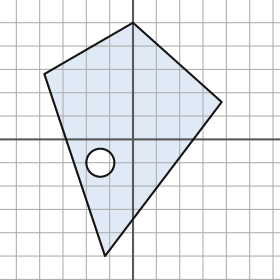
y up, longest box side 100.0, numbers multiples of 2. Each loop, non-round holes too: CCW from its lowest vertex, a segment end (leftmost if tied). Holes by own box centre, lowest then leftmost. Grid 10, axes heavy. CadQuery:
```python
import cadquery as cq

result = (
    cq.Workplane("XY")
    .moveTo(-12.0, -50.0)
    .lineTo(38.0, 16.0)
    .lineTo(0.0, 50.0)
    .lineTo(-38.0, 28.0)
    .close()
    .moveTo(-14.0, -10.0)
    .circle(6.0)
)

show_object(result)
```